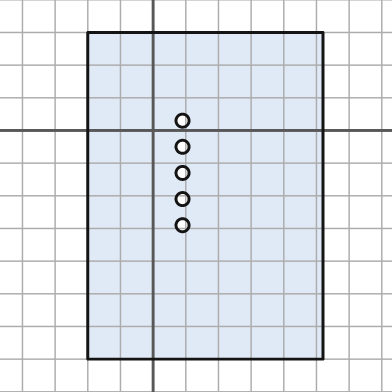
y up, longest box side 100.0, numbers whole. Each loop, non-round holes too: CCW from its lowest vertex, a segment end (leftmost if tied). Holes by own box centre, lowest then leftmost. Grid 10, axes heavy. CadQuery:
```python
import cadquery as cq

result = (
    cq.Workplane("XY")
    .moveTo(-20.0, -70.0)
    .lineTo(52.0, -70.0)
    .lineTo(52.0, 30.0)
    .lineTo(-20.0, 30.0)
    .close()
    .moveTo(9.0, -29.0)
    .circle(2.0)
    .moveTo(9.0, -21.0)
    .circle(2.0)
    .moveTo(9.0, -13.0)
    .circle(2.0)
    .moveTo(9.0, -5.0)
    .circle(2.0)
    .moveTo(9.0, 3.0)
    .circle(2.0)
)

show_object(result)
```